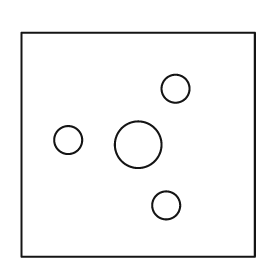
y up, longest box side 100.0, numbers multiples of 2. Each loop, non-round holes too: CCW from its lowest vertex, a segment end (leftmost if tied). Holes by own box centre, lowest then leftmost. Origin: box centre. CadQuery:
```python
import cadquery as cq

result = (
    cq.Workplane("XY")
    .moveTo(-50.0, -48.0)
    .lineTo(50.0, -48.0)
    .lineTo(50.0, 48.0)
    .lineTo(-50.0, 48.0)
    .close()
    .moveTo(12.0, -26.0)
    .circle(6.0)
    .moveTo(0.0, 0.0)
    .circle(10.0)
    .moveTo(-30.0, 2.0)
    .circle(6.0)
    .moveTo(16.0, 24.0)
    .circle(6.0)
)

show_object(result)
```